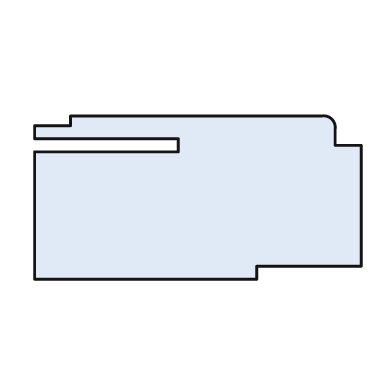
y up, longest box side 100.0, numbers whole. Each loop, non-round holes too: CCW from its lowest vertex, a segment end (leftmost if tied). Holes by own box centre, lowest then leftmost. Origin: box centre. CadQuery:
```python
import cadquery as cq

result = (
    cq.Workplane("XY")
    .moveTo(-50.0, -25.0)
    .lineTo(18.0, -25.0)
    .lineTo(18.0, -21.0)
    .lineTo(50.0, -21.0)
    .lineTo(50.0, 16.0)
    .lineTo(42.0, 16.0)
    .lineTo(42.0, 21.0)
    .threePointArc((41.0, 24.0), (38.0, 25.0))
    .lineTo(-39.0, 25.0)
    .lineTo(-39.0, 22.0)
    .lineTo(-50.0, 22.0)
    .lineTo(-50.0, 18.0)
    .lineTo(-6.0, 18.0)
    .lineTo(-6.0, 14.0)
    .lineTo(-50.0, 14.0)
    .close()
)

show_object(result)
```